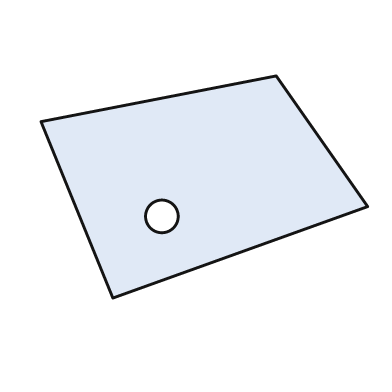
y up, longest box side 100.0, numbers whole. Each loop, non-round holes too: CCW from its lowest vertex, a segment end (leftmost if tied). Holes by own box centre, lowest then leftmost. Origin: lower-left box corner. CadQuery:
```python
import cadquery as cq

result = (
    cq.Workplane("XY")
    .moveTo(22.0, 0.0)
    .lineTo(100.0, 28.0)
    .lineTo(72.0, 68.0)
    .lineTo(0.0, 54.0)
    .close()
    .moveTo(37.0, 25.0)
    .circle(5.0)
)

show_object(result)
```